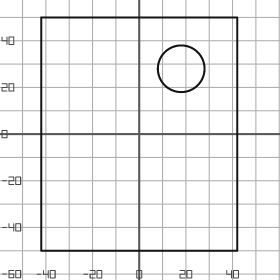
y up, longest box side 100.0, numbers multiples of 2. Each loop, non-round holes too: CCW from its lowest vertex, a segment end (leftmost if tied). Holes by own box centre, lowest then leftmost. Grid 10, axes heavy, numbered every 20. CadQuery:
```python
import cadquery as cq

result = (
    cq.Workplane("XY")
    .moveTo(-42.0, -50.0)
    .lineTo(42.0, -50.0)
    .lineTo(42.0, 50.0)
    .lineTo(-42.0, 50.0)
    .close()
    .moveTo(18.0, 28.0)
    .circle(10.0)
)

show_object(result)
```